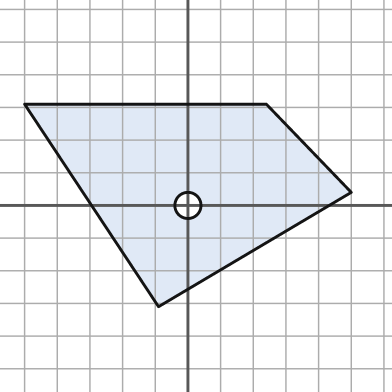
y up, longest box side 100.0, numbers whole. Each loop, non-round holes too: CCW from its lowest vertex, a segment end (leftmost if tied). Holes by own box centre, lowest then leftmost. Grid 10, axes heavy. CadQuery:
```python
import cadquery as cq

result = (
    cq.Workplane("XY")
    .moveTo(-9.0, -31.0)
    .lineTo(50.0, 4.0)
    .lineTo(24.0, 31.0)
    .lineTo(-50.0, 31.0)
    .close()
    .moveTo(0.0, 0.0)
    .circle(4.0)
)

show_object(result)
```